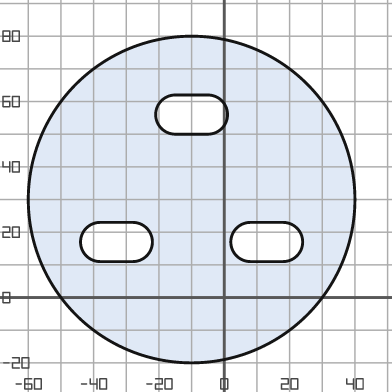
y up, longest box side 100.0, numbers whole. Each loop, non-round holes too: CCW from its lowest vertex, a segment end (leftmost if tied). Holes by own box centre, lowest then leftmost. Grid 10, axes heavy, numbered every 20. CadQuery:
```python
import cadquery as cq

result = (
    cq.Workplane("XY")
    .moveTo(-10.0, 30.0)
    .circle(50.0)
    .moveTo(-38.0, 11.0)
    .lineTo(-28.0, 11.0)
    .threePointArc((-22.0, 17.0), (-28.0, 23.0))
    .lineTo(-38.0, 23.0)
    .threePointArc((-44.0, 17.0), (-38.0, 11.0))
    .close()
    .moveTo(8.0, 11.0)
    .lineTo(18.0, 11.0)
    .threePointArc((24.0, 17.0), (18.0, 23.0))
    .lineTo(8.0, 23.0)
    .threePointArc((2.0, 17.0), (8.0, 11.0))
    .close()
    .moveTo(-15.0, 50.0)
    .lineTo(-5.0, 50.0)
    .threePointArc((1.0, 56.0), (-5.0, 62.0))
    .lineTo(-15.0, 62.0)
    .threePointArc((-21.0, 56.0), (-15.0, 50.0))
    .close()
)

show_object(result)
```